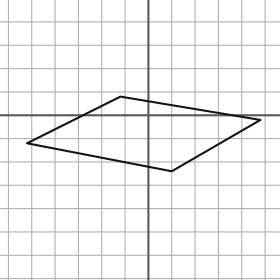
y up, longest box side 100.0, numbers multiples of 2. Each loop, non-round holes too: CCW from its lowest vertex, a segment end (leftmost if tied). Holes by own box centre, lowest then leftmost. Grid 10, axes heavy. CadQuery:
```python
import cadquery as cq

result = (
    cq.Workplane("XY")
    .moveTo(10.0, -24.0)
    .lineTo(48.0, -2.0)
    .lineTo(-12.0, 8.0)
    .lineTo(-52.0, -12.0)
    .close()
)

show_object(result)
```